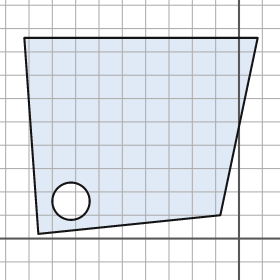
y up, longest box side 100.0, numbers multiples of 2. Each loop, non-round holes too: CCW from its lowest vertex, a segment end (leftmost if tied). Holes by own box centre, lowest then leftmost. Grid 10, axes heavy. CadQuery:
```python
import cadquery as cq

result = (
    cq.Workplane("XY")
    .moveTo(-86.0, 2.0)
    .lineTo(-8.0, 10.0)
    .lineTo(8.0, 86.0)
    .lineTo(-92.0, 86.0)
    .close()
    .moveTo(-72.0, 16.0)
    .circle(8.0)
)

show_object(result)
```